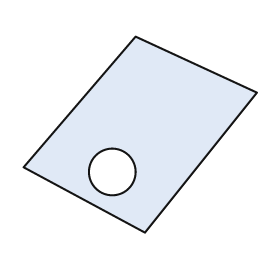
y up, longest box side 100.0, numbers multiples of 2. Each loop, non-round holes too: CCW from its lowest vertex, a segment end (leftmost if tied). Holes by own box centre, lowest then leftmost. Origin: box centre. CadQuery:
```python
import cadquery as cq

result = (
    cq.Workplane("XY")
    .moveTo(2.0, -42.0)
    .lineTo(50.0, 18.0)
    .lineTo(-2.0, 42.0)
    .lineTo(-50.0, -14.0)
    .close()
    .moveTo(-12.0, -16.0)
    .circle(10.0)
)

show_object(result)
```